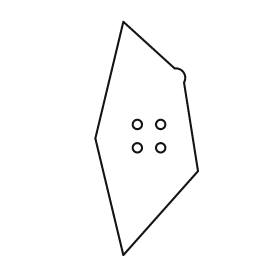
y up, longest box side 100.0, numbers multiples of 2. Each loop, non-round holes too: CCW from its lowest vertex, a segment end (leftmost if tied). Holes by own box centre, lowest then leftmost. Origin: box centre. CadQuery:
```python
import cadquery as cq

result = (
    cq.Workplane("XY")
    .moveTo(-10.0, -50.0)
    .lineTo(22.0, -14.0)
    .lineTo(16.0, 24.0)
    .threePointArc((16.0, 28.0), (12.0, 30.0))
    .lineTo(-10.0, 50.0)
    .lineTo(-22.0, 0.0)
    .close()
    .moveTo(-4.0, -4.0)
    .circle(2.0)
    .moveTo(6.0, -4.0)
    .circle(2.0)
    .moveTo(-4.0, 6.0)
    .circle(2.0)
    .moveTo(6.0, 6.0)
    .circle(2.0)
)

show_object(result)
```